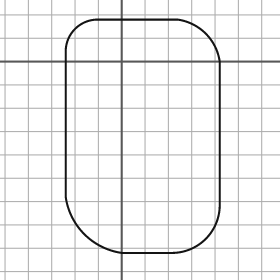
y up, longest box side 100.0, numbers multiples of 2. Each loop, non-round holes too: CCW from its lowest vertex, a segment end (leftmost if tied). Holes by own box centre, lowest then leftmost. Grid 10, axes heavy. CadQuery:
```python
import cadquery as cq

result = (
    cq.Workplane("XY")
    .moveTo(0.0, -82.0)
    .lineTo(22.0, -82.0)
    .threePointArc((36.0, -76.0), (42.0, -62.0))
    .lineTo(42.0, 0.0)
    .threePointArc((36.0, 12.0), (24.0, 18.0))
    .lineTo(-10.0, 18.0)
    .threePointArc((-20.0, 14.0), (-24.0, 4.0))
    .lineTo(-24.0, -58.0)
    .threePointArc((-16.0, -74.0), (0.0, -82.0))
    .close()
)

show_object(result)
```